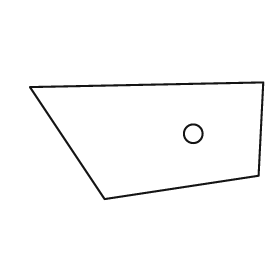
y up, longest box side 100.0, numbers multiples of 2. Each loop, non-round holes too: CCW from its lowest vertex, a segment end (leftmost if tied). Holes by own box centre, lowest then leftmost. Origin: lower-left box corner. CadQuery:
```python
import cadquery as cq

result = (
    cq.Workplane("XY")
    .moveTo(32.0, 0.0)
    .lineTo(98.0, 10.0)
    .lineTo(100.0, 50.0)
    .lineTo(0.0, 48.0)
    .close()
    .moveTo(70.0, 28.0)
    .circle(4.0)
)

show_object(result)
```